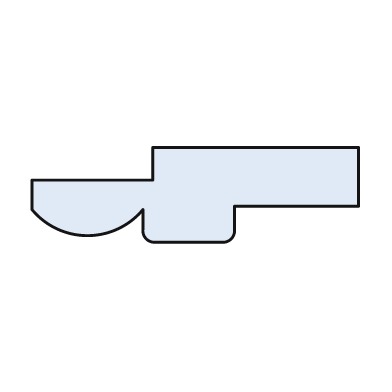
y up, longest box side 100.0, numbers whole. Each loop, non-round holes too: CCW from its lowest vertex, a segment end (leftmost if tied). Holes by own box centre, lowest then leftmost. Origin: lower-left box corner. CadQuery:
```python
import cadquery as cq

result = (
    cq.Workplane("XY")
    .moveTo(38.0, 0.0)
    .lineTo(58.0, 0.0)
    .threePointArc((61.0, 1.0), (62.0, 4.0))
    .lineTo(62.0, 11.0)
    .lineTo(100.0, 11.0)
    .lineTo(100.0, 29.0)
    .lineTo(37.0, 29.0)
    .lineTo(37.0, 19.0)
    .lineTo(0.0, 19.0)
    .lineTo(0.0, 10.0)
    .threePointArc((17.0, 2.0), (34.0, 10.0))
    .lineTo(34.0, 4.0)
    .threePointArc((35.0, 1.0), (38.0, 0.0))
    .close()
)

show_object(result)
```